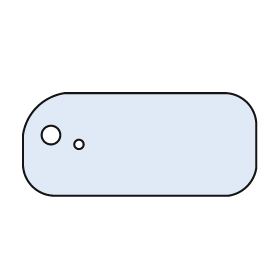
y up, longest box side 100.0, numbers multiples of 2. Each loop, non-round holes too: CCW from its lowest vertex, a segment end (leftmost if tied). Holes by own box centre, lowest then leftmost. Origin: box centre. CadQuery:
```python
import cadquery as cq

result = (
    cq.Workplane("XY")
    .moveTo(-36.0, -22.0)
    .lineTo(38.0, -22.0)
    .threePointArc((46.0, -18.0), (50.0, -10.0))
    .lineTo(50.0, 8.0)
    .threePointArc((46.0, 18.0), (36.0, 22.0))
    .lineTo(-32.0, 22.0)
    .threePointArc((-44.0, 16.0), (-50.0, 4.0))
    .lineTo(-50.0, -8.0)
    .threePointArc((-46.0, -18.0), (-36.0, -22.0))
    .close()
    .moveTo(-26.0, 0.0)
    .circle(2.0)
    .moveTo(-38.0, 4.0)
    .circle(4.0)
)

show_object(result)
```